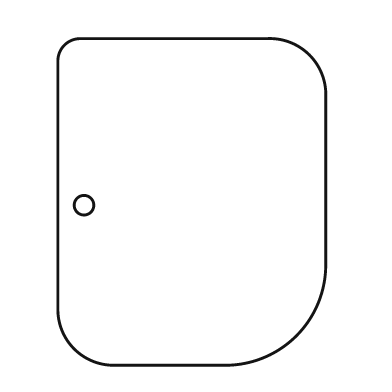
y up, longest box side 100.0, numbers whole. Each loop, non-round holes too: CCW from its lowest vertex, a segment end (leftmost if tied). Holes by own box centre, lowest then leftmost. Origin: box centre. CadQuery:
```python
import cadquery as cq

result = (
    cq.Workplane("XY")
    .moveTo(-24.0, -50.0)
    .lineTo(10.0, -50.0)
    .threePointArc((32.0, -41.0), (41.0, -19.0))
    .lineTo(41.0, 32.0)
    .threePointArc((36.0, 45.0), (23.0, 50.0))
    .lineTo(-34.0, 50.0)
    .threePointArc((-39.0, 48.0), (-41.0, 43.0))
    .lineTo(-41.0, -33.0)
    .threePointArc((-36.0, -45.0), (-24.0, -50.0))
    .close()
    .moveTo(-33.0, -1.0)
    .circle(3.0)
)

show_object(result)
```